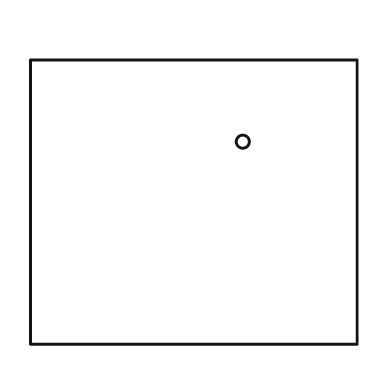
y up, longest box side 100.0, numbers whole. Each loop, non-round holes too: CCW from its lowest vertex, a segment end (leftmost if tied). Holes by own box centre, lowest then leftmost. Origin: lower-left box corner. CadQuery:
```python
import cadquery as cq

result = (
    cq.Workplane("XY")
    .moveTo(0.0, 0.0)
    .lineTo(100.0, 0.0)
    .lineTo(100.0, 87.0)
    .lineTo(0.0, 87.0)
    .close()
    .moveTo(65.0, 62.0)
    .circle(2.0)
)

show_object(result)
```